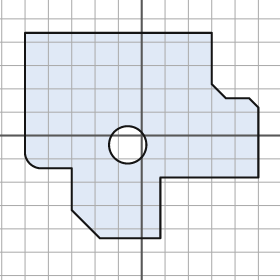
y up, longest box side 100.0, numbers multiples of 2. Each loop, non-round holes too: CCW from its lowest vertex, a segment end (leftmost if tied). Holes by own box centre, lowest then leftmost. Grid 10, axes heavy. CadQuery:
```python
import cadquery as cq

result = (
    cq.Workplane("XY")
    .moveTo(-18.0, -44.0)
    .lineTo(8.0, -44.0)
    .lineTo(8.0, -18.0)
    .lineTo(50.0, -18.0)
    .lineTo(50.0, 12.0)
    .lineTo(46.0, 16.0)
    .lineTo(36.0, 16.0)
    .lineTo(30.0, 22.0)
    .lineTo(30.0, 44.0)
    .lineTo(-50.0, 44.0)
    .lineTo(-50.0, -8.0)
    .threePointArc((-48.0, -12.0), (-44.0, -14.0))
    .lineTo(-30.0, -14.0)
    .lineTo(-30.0, -32.0)
    .close()
    .moveTo(-6.0, -4.0)
    .circle(8.0)
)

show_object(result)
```